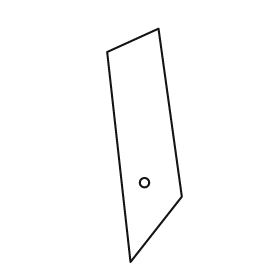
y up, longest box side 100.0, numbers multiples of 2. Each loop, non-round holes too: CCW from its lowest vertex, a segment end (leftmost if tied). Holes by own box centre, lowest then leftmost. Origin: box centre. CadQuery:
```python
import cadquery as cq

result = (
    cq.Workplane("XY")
    .moveTo(-6.0, -50.0)
    .lineTo(16.0, -22.0)
    .lineTo(6.0, 50.0)
    .lineTo(-16.0, 40.0)
    .close()
    .moveTo(0.0, -16.0)
    .circle(2.0)
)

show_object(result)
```